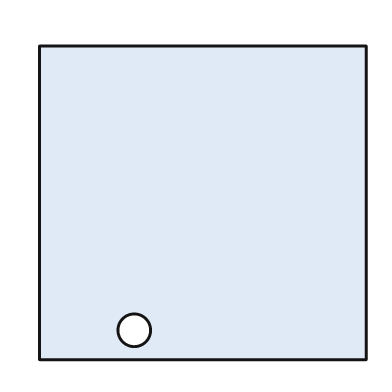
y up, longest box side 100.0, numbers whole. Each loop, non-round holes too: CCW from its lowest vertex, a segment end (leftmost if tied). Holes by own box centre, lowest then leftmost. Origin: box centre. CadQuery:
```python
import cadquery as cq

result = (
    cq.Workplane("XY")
    .moveTo(-50.0, -48.0)
    .lineTo(50.0, -48.0)
    .lineTo(50.0, 48.0)
    .lineTo(-50.0, 48.0)
    .close()
    .moveTo(-21.0, -39.0)
    .circle(5.0)
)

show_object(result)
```